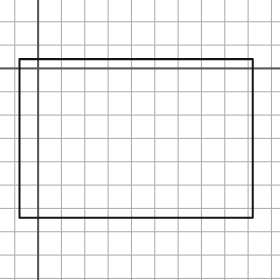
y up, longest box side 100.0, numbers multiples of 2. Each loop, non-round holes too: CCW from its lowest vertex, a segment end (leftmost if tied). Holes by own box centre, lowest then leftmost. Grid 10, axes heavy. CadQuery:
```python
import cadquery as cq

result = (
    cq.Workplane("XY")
    .moveTo(-8.0, -64.0)
    .lineTo(92.0, -64.0)
    .lineTo(92.0, 4.0)
    .lineTo(-8.0, 4.0)
    .close()
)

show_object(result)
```